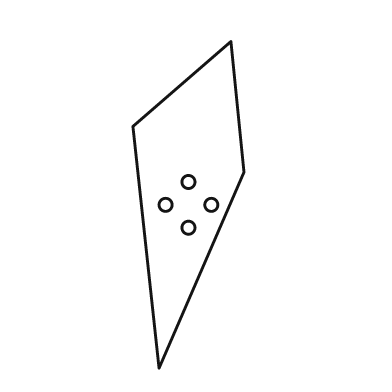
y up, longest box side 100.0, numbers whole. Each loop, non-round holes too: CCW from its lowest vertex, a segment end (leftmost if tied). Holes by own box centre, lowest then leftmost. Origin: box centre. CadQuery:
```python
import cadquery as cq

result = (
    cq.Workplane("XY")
    .moveTo(-9.0, -50.0)
    .lineTo(17.0, 10.0)
    .lineTo(13.0, 50.0)
    .lineTo(-17.0, 24.0)
    .close()
    .moveTo(0.0, -7.0)
    .circle(2.0)
    .moveTo(-7.0, 0.0)
    .circle(2.0)
    .moveTo(7.0, 0.0)
    .circle(2.0)
    .moveTo(0.0, 7.0)
    .circle(2.0)
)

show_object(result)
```